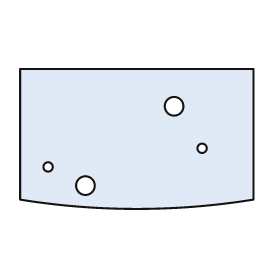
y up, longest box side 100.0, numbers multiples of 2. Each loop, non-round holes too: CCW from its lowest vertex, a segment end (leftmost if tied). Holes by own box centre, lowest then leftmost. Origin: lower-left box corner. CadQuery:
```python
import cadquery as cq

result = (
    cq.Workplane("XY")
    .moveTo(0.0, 4.0)
    .threePointArc((50.0, 0.0), (100.0, 4.0))
    .lineTo(100.0, 60.0)
    .lineTo(0.0, 60.0)
    .close()
    .moveTo(28.0, 10.0)
    .circle(4.0)
    .moveTo(12.0, 18.0)
    .circle(2.0)
    .moveTo(78.0, 26.0)
    .circle(2.0)
    .moveTo(66.0, 44.0)
    .circle(4.0)
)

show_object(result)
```